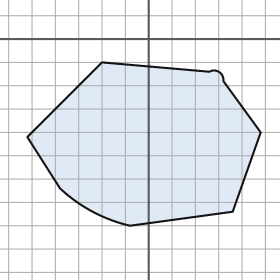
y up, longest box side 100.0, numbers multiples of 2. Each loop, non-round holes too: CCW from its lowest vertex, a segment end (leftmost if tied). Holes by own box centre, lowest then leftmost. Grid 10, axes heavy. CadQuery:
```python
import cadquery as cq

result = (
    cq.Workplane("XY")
    .moveTo(-8.0, -80.0)
    .lineTo(36.0, -74.0)
    .lineTo(48.0, -40.0)
    .lineTo(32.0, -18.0)
    .threePointArc((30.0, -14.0), (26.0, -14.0))
    .lineTo(-20.0, -10.0)
    .lineTo(-52.0, -42.0)
    .lineTo(-38.0, -64.0)
    .threePointArc((-24.0, -74.0), (-8.0, -80.0))
    .close()
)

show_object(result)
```